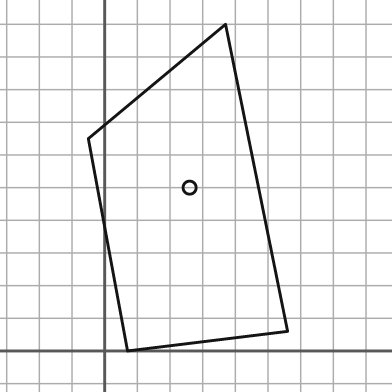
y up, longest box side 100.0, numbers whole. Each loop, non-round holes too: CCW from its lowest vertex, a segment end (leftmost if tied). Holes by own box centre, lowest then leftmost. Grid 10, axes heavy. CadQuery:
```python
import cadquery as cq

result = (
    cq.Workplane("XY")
    .moveTo(7.0, 0.0)
    .lineTo(56.0, 6.0)
    .lineTo(37.0, 100.0)
    .lineTo(-5.0, 65.0)
    .close()
    .moveTo(26.0, 50.0)
    .circle(2.0)
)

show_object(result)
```